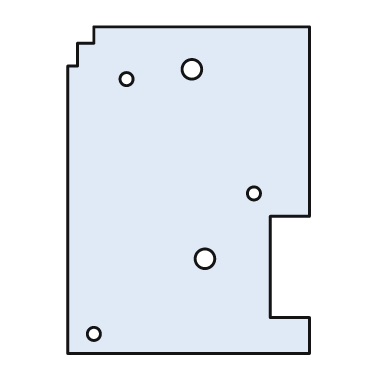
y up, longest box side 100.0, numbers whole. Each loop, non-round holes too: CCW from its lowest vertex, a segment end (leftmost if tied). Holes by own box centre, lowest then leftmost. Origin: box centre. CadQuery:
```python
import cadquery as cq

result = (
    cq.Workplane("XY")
    .moveTo(-37.0, -50.0)
    .lineTo(37.0, -50.0)
    .lineTo(37.0, -39.0)
    .lineTo(25.0, -39.0)
    .lineTo(25.0, -8.0)
    .lineTo(37.0, -8.0)
    .lineTo(37.0, 50.0)
    .lineTo(-29.0, 50.0)
    .lineTo(-29.0, 45.0)
    .lineTo(-34.0, 45.0)
    .lineTo(-34.0, 38.0)
    .lineTo(-37.0, 38.0)
    .close()
    .moveTo(-29.0, -44.0)
    .circle(2.0)
    .moveTo(5.0, -21.0)
    .circle(3.0)
    .moveTo(20.0, -1.0)
    .circle(2.0)
    .moveTo(-19.0, 34.0)
    .circle(2.0)
    .moveTo(1.0, 37.0)
    .circle(3.0)
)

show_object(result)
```